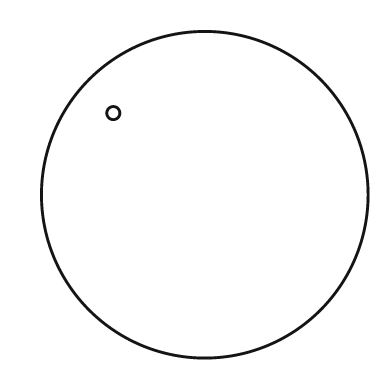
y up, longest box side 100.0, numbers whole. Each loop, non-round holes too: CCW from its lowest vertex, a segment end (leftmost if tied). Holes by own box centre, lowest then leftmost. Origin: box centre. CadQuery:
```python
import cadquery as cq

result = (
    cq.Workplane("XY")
    .moveTo(0.0, 0.0)
    .circle(50.0)
    .moveTo(-28.0, 25.0)
    .circle(2.0)
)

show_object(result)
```